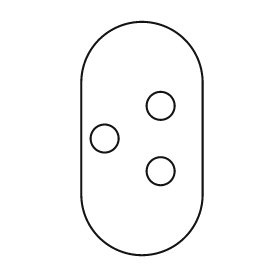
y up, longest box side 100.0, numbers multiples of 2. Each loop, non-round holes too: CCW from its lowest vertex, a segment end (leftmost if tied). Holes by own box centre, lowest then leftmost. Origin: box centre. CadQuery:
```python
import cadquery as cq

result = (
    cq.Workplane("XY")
    .moveTo(-26.0, -24.0)
    .threePointArc((0.0, -50.0), (26.0, -24.0))
    .lineTo(26.0, 24.0)
    .threePointArc((0.0, 50.0), (-26.0, 24.0))
    .close()
    .moveTo(8.0, -14.0)
    .circle(6.0)
    .moveTo(-16.0, 0.0)
    .circle(6.0)
    .moveTo(8.0, 14.0)
    .circle(6.0)
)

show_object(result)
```